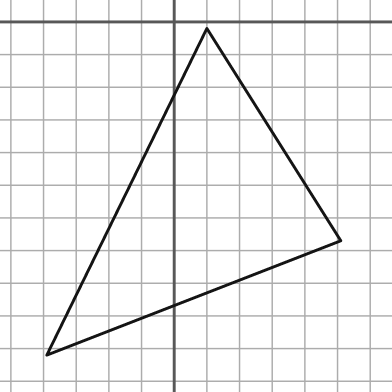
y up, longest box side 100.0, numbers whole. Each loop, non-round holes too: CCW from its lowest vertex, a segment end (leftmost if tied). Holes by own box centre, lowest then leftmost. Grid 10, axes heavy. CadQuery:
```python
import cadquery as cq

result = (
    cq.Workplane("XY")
    .moveTo(-39.0, -102.0)
    .lineTo(51.0, -67.0)
    .lineTo(10.0, -2.0)
    .close()
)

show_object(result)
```